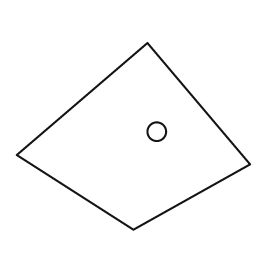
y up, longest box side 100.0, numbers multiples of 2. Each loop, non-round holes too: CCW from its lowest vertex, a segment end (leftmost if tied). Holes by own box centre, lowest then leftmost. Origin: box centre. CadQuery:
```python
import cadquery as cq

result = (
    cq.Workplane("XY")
    .moveTo(0.0, -40.0)
    .lineTo(50.0, -12.0)
    .lineTo(6.0, 40.0)
    .lineTo(-50.0, -8.0)
    .close()
    .moveTo(10.0, 2.0)
    .circle(4.0)
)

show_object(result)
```